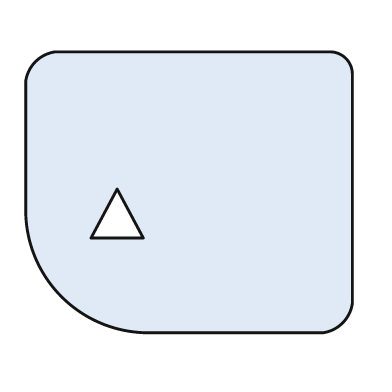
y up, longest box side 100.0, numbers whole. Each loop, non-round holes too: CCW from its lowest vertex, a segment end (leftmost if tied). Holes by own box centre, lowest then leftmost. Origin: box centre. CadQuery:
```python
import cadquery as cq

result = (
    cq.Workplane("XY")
    .moveTo(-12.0, -43.0)
    .lineTo(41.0, -43.0)
    .threePointArc((47.0, -40.0), (50.0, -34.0))
    .lineTo(50.0, 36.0)
    .threePointArc((48.0, 41.0), (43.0, 43.0))
    .lineTo(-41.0, 43.0)
    .threePointArc((-47.0, 40.0), (-50.0, 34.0))
    .lineTo(-50.0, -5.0)
    .threePointArc((-39.0, -32.0), (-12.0, -43.0))
    .close()
    .moveTo(-30.0, -14.0)
    .lineTo(-14.0, -14.0)
    .lineTo(-22.0, 1.0)
    .close()
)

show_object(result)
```